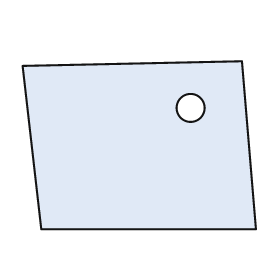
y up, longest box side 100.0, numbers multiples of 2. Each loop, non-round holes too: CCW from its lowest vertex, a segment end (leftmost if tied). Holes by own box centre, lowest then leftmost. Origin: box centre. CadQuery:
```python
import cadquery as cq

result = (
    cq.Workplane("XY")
    .moveTo(-42.0, -36.0)
    .lineTo(50.0, -36.0)
    .lineTo(44.0, 36.0)
    .lineTo(-50.0, 34.0)
    .close()
    .moveTo(22.0, 16.0)
    .circle(6.0)
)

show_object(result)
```